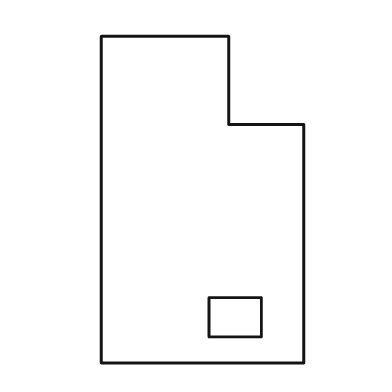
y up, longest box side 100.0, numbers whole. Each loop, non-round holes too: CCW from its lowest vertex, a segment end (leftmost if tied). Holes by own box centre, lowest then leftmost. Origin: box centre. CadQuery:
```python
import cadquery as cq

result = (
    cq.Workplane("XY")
    .moveTo(-31.0, -50.0)
    .lineTo(31.0, -50.0)
    .lineTo(31.0, 23.0)
    .lineTo(8.0, 23.0)
    .lineTo(8.0, 50.0)
    .lineTo(-31.0, 50.0)
    .close()
    .moveTo(2.0, -42.0)
    .lineTo(18.0, -42.0)
    .lineTo(18.0, -30.0)
    .lineTo(2.0, -30.0)
    .close()
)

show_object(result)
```